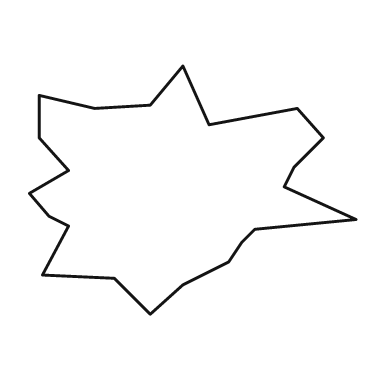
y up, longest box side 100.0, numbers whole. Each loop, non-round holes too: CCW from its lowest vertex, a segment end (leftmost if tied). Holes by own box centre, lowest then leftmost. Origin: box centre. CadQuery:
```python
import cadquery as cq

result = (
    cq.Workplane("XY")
    .moveTo(-13.0, -38.0)
    .lineTo(-3.0, -29.0)
    .lineTo(11.0, -22.0)
    .lineTo(15.0, -16.0)
    .lineTo(19.0, -12.0)
    .lineTo(50.0, -9.0)
    .lineTo(28.0, 1.0)
    .lineTo(31.0, 7.0)
    .lineTo(40.0, 16.0)
    .lineTo(32.0, 25.0)
    .lineTo(5.0, 20.0)
    .lineTo(-3.0, 38.0)
    .lineTo(-13.0, 26.0)
    .lineTo(-30.0, 25.0)
    .lineTo(-47.0, 29.0)
    .lineTo(-47.0, 16.0)
    .lineTo(-38.0, 6.0)
    .lineTo(-50.0, -1.0)
    .lineTo(-44.0, -8.0)
    .lineTo(-38.0, -11.0)
    .lineTo(-46.0, -26.0)
    .lineTo(-24.0, -27.0)
    .close()
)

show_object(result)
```